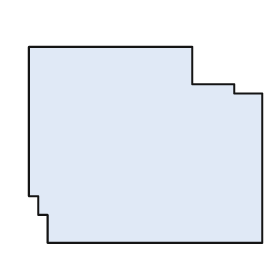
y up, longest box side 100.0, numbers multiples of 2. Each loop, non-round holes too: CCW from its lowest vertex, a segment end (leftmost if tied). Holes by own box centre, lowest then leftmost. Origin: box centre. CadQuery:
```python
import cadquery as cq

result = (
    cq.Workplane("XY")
    .moveTo(-42.0, -42.0)
    .lineTo(50.0, -42.0)
    .lineTo(50.0, 22.0)
    .lineTo(38.0, 22.0)
    .lineTo(38.0, 26.0)
    .lineTo(20.0, 26.0)
    .lineTo(20.0, 42.0)
    .lineTo(-50.0, 42.0)
    .lineTo(-50.0, -22.0)
    .lineTo(-46.0, -22.0)
    .lineTo(-46.0, -30.0)
    .lineTo(-42.0, -30.0)
    .close()
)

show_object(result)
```